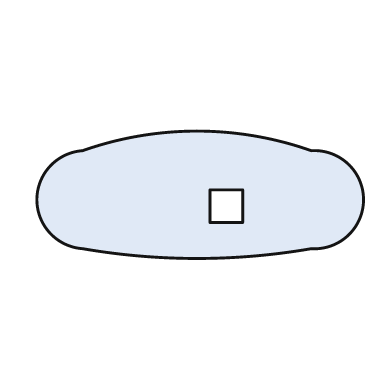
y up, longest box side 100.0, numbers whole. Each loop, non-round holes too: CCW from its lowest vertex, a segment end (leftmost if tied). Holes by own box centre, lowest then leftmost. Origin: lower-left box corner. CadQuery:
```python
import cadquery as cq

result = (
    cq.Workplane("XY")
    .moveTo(14.0, 3.0)
    .threePointArc((49.0, 0.0), (84.0, 3.0))
    .threePointArc((100.0, 18.0), (84.0, 33.0))
    .threePointArc((49.0, 39.0), (14.0, 33.0))
    .threePointArc((0.0, 18.0), (14.0, 3.0))
    .close()
    .moveTo(53.0, 11.0)
    .lineTo(63.0, 11.0)
    .lineTo(63.0, 21.0)
    .lineTo(53.0, 21.0)
    .close()
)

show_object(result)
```